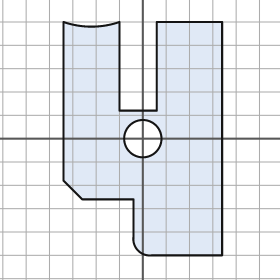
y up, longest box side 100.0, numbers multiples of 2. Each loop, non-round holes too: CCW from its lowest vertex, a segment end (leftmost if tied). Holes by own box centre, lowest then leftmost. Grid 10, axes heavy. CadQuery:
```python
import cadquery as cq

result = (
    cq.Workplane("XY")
    .moveTo(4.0, -50.0)
    .lineTo(34.0, -50.0)
    .lineTo(34.0, 50.0)
    .lineTo(6.0, 50.0)
    .lineTo(6.0, 12.0)
    .lineTo(-10.0, 12.0)
    .lineTo(-10.0, 50.0)
    .threePointArc((-22.0, 48.0), (-34.0, 50.0))
    .lineTo(-34.0, -18.0)
    .lineTo(-26.0, -26.0)
    .lineTo(-4.0, -26.0)
    .lineTo(-4.0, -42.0)
    .threePointArc((-2.0, -48.0), (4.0, -50.0))
    .close()
    .moveTo(0.0, 0.0)
    .circle(8.0)
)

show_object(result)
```